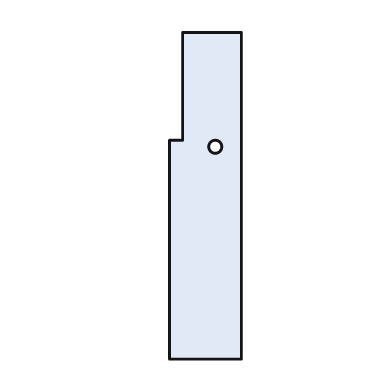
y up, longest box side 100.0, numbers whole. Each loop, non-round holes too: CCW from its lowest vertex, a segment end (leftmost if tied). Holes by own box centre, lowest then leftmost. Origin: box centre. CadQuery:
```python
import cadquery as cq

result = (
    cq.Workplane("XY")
    .moveTo(-11.0, -50.0)
    .lineTo(11.0, -50.0)
    .lineTo(11.0, 50.0)
    .lineTo(-7.0, 50.0)
    .lineTo(-7.0, 17.0)
    .lineTo(-11.0, 17.0)
    .close()
    .moveTo(3.0, 15.0)
    .circle(2.0)
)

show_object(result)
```